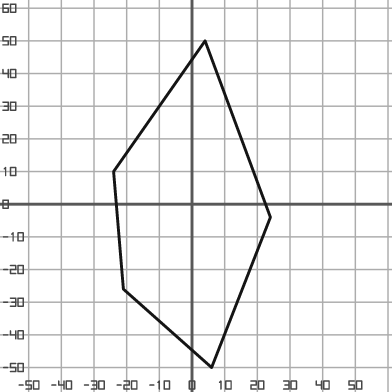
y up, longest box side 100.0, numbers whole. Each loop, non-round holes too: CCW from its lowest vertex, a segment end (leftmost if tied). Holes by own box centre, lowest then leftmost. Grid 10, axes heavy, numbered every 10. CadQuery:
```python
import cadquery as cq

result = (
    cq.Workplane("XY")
    .moveTo(6.0, -50.0)
    .lineTo(24.0, -4.0)
    .lineTo(4.0, 50.0)
    .lineTo(-24.0, 10.0)
    .lineTo(-21.0, -26.0)
    .close()
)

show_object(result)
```